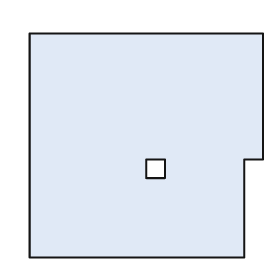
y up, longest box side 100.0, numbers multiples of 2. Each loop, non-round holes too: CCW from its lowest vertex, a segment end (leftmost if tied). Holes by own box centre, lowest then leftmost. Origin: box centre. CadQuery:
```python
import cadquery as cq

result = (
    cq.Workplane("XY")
    .moveTo(-50.0, -48.0)
    .lineTo(42.0, -48.0)
    .lineTo(42.0, -6.0)
    .lineTo(50.0, -6.0)
    .lineTo(50.0, 48.0)
    .lineTo(-50.0, 48.0)
    .close()
    .moveTo(0.0, -14.0)
    .lineTo(8.0, -14.0)
    .lineTo(8.0, -6.0)
    .lineTo(0.0, -6.0)
    .close()
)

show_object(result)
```